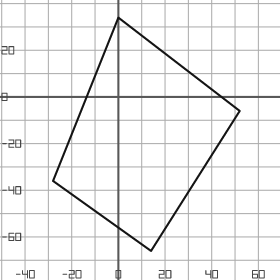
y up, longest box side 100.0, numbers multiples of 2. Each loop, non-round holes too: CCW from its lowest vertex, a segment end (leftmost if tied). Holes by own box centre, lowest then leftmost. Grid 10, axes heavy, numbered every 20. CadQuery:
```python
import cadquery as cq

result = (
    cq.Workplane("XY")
    .moveTo(14.0, -66.0)
    .lineTo(52.0, -6.0)
    .lineTo(0.0, 34.0)
    .lineTo(-28.0, -36.0)
    .close()
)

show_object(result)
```